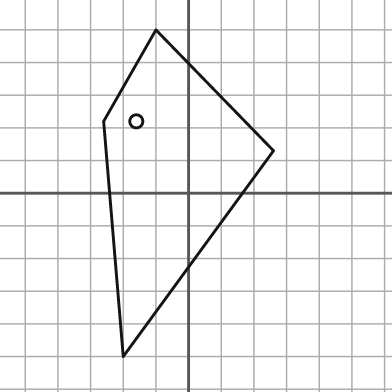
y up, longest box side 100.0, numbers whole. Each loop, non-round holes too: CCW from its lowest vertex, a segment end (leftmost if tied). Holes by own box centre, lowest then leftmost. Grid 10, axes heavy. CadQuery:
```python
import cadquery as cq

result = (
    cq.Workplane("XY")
    .moveTo(-20.0, -50.0)
    .lineTo(26.0, 13.0)
    .lineTo(-10.0, 50.0)
    .lineTo(-26.0, 22.0)
    .close()
    .moveTo(-16.0, 22.0)
    .circle(2.0)
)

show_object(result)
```